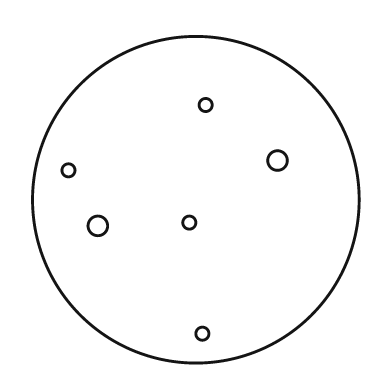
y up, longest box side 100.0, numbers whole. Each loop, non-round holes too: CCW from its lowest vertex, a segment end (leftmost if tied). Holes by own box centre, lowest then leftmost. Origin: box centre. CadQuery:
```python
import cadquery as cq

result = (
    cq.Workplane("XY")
    .moveTo(0.0, 0.0)
    .circle(50.0)
    .moveTo(2.0, -41.0)
    .circle(2.0)
    .moveTo(-30.0, -8.0)
    .circle(3.0)
    .moveTo(-2.0, -7.0)
    .circle(2.0)
    .moveTo(-39.0, 9.0)
    .circle(2.0)
    .moveTo(25.0, 12.0)
    .circle(3.0)
    .moveTo(3.0, 29.0)
    .circle(2.0)
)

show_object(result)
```